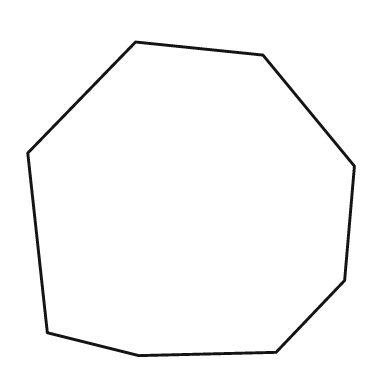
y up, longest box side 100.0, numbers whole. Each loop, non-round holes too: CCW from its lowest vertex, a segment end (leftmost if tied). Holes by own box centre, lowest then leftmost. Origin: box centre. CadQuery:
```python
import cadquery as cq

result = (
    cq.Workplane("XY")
    .moveTo(-16.0, -48.0)
    .lineTo(26.0, -47.0)
    .lineTo(47.0, -25.0)
    .lineTo(50.0, 10.0)
    .lineTo(22.0, 44.0)
    .lineTo(-17.0, 48.0)
    .lineTo(-50.0, 14.0)
    .lineTo(-44.0, -41.0)
    .close()
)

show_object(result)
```